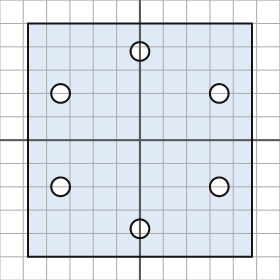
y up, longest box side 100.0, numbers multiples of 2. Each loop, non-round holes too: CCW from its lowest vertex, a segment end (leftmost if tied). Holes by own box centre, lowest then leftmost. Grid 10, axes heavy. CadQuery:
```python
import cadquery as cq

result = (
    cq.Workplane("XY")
    .moveTo(-48.0, -50.0)
    .lineTo(48.0, -50.0)
    .lineTo(48.0, 50.0)
    .lineTo(-48.0, 50.0)
    .close()
    .moveTo(0.0, -38.0)
    .circle(4.0)
    .moveTo(-34.0, -20.0)
    .circle(4.0)
    .moveTo(34.0, -20.0)
    .circle(4.0)
    .moveTo(-34.0, 20.0)
    .circle(4.0)
    .moveTo(34.0, 20.0)
    .circle(4.0)
    .moveTo(0.0, 38.0)
    .circle(4.0)
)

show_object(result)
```